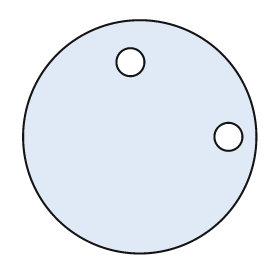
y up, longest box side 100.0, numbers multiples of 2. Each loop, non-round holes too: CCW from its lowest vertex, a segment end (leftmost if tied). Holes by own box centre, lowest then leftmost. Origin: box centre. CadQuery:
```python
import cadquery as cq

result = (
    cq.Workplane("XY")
    .moveTo(0.0, 0.0)
    .circle(50.0)
    .moveTo(38.0, 0.0)
    .circle(6.0)
    .moveTo(-4.0, 32.0)
    .circle(6.0)
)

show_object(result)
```